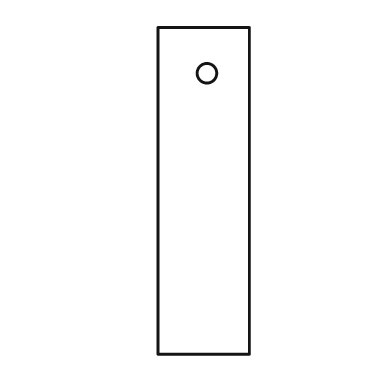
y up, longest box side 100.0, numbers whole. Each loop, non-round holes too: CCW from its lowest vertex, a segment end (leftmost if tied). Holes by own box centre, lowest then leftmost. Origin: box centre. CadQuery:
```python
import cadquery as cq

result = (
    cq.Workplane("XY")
    .moveTo(-14.0, -50.0)
    .lineTo(14.0, -50.0)
    .lineTo(14.0, 50.0)
    .lineTo(-14.0, 50.0)
    .close()
    .moveTo(1.0, 36.0)
    .circle(3.0)
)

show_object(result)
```